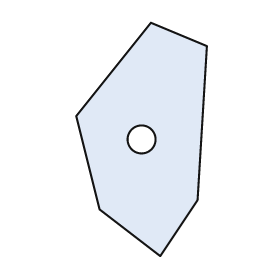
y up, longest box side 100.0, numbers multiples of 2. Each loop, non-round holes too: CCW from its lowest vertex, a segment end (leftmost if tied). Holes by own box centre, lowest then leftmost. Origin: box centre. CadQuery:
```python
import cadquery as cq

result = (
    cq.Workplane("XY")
    .moveTo(8.0, -50.0)
    .lineTo(24.0, -26.0)
    .lineTo(28.0, 40.0)
    .lineTo(4.0, 50.0)
    .lineTo(-28.0, 10.0)
    .lineTo(-18.0, -30.0)
    .close()
    .moveTo(0.0, 0.0)
    .circle(6.0)
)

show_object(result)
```